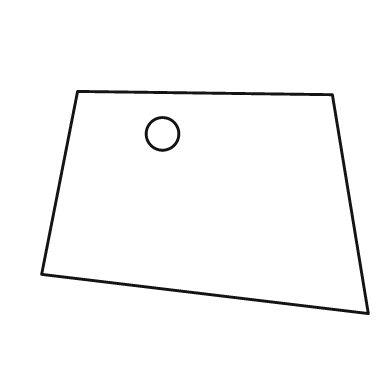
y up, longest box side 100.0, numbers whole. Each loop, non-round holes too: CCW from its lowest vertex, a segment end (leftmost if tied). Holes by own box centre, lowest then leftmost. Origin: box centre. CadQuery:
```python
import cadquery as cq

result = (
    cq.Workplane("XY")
    .moveTo(50.0, -34.0)
    .lineTo(39.0, 33.0)
    .lineTo(-39.0, 34.0)
    .lineTo(-50.0, -22.0)
    .close()
    .moveTo(-13.0, 21.0)
    .circle(5.0)
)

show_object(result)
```